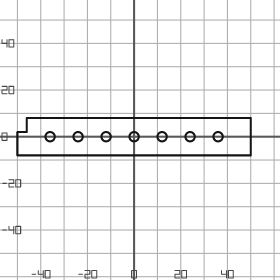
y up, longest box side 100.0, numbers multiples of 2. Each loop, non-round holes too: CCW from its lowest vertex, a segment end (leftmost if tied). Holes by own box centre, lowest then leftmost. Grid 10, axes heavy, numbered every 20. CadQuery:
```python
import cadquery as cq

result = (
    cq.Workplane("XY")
    .moveTo(-50.0, -8.0)
    .lineTo(50.0, -8.0)
    .lineTo(50.0, 8.0)
    .lineTo(-46.0, 8.0)
    .lineTo(-46.0, 2.0)
    .lineTo(-50.0, 2.0)
    .close()
    .moveTo(-36.0, 0.0)
    .circle(2.0)
    .moveTo(-24.0, 0.0)
    .circle(2.0)
    .moveTo(-12.0, 0.0)
    .circle(2.0)
    .moveTo(0.0, 0.0)
    .circle(2.0)
    .moveTo(12.0, 0.0)
    .circle(2.0)
    .moveTo(24.0, 0.0)
    .circle(2.0)
    .moveTo(36.0, 0.0)
    .circle(2.0)
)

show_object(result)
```